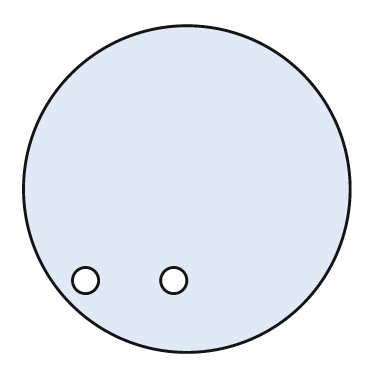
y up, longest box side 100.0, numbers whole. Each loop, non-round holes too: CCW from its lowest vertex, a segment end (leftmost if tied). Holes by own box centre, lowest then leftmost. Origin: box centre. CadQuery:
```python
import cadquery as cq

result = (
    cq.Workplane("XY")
    .moveTo(0.0, 0.0)
    .circle(50.0)
    .moveTo(-31.0, -28.0)
    .circle(4.0)
    .moveTo(-4.0, -28.0)
    .circle(4.0)
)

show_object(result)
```